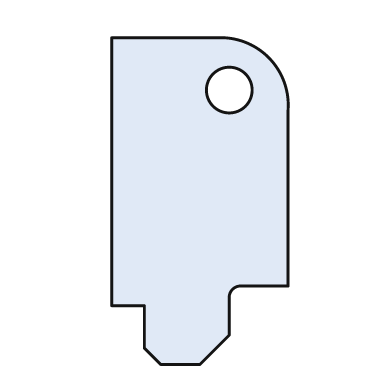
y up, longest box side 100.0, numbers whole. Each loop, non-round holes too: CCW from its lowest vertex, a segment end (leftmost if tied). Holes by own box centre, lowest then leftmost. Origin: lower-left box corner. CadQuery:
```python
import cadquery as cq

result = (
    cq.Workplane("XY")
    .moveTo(15.0, 0.0)
    .lineTo(27.0, 0.0)
    .lineTo(36.0, 9.0)
    .lineTo(36.0, 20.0)
    .threePointArc((37.0, 23.0), (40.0, 24.0))
    .lineTo(54.0, 24.0)
    .lineTo(54.0, 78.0)
    .threePointArc((48.0, 94.0), (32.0, 100.0))
    .lineTo(0.0, 100.0)
    .lineTo(0.0, 18.0)
    .lineTo(10.0, 18.0)
    .lineTo(10.0, 5.0)
    .close()
    .moveTo(36.0, 84.0)
    .circle(7.0)
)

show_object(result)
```